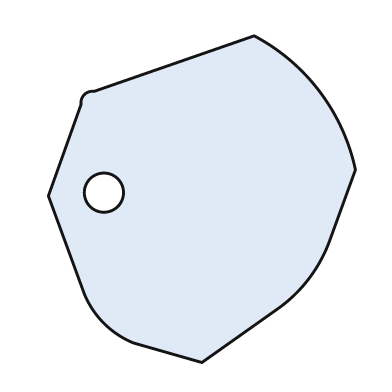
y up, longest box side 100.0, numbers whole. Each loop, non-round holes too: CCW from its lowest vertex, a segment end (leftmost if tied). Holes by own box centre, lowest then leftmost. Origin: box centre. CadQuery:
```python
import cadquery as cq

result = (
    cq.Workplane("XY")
    .moveTo(0.0, -50.0)
    .lineTo(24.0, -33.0)
    .threePointArc((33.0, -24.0), (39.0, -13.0))
    .lineTo(47.0, 9.0)
    .threePointArc((36.0, 33.0), (16.0, 50.0))
    .lineTo(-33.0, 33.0)
    .threePointArc((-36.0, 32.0), (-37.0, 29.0))
    .lineTo(-47.0, 1.0)
    .lineTo(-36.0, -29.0)
    .threePointArc((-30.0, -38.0), (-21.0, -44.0))
    .close()
    .moveTo(-30.0, 2.0)
    .circle(6.0)
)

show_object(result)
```